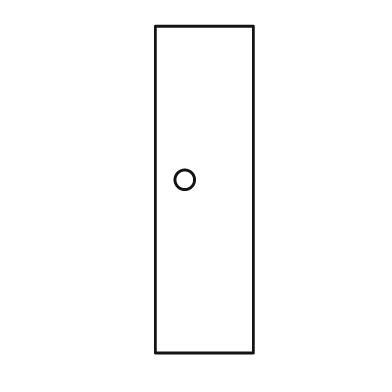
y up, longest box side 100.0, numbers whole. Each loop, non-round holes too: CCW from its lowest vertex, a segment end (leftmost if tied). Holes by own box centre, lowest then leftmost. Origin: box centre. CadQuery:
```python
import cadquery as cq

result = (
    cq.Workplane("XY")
    .moveTo(-15.0, -50.0)
    .lineTo(15.0, -50.0)
    .lineTo(15.0, 50.0)
    .lineTo(-15.0, 50.0)
    .close()
    .moveTo(-6.0, 3.0)
    .circle(3.0)
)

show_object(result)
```